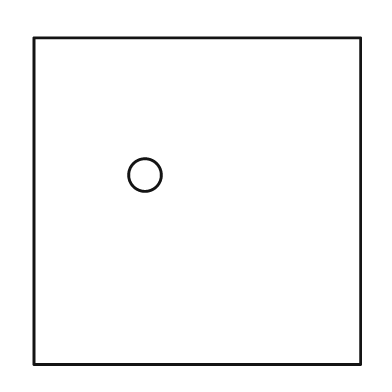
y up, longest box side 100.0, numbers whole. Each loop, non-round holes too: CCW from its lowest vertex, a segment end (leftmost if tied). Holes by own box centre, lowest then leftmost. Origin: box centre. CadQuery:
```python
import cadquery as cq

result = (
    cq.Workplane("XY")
    .moveTo(-50.0, -50.0)
    .lineTo(50.0, -50.0)
    .lineTo(50.0, 50.0)
    .lineTo(-50.0, 50.0)
    .close()
    .moveTo(-16.0, 8.0)
    .circle(5.0)
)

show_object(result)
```